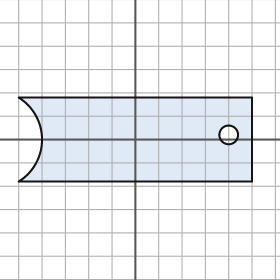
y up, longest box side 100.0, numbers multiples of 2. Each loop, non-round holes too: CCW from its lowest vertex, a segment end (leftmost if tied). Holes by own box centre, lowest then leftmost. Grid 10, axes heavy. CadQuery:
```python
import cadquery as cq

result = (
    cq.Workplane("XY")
    .moveTo(-50.0, -18.0)
    .lineTo(50.0, -18.0)
    .lineTo(50.0, 18.0)
    .lineTo(-50.0, 18.0)
    .threePointArc((-40.0, 0.0), (-50.0, -18.0))
    .close()
    .moveTo(40.0, 2.0)
    .circle(4.0)
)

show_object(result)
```